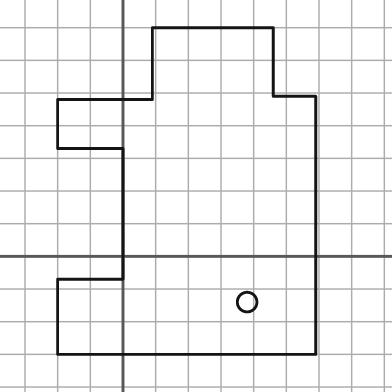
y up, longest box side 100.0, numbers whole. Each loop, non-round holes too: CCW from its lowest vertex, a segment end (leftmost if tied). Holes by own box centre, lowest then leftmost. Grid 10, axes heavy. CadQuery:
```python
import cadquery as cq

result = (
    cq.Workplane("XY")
    .moveTo(-20.0, -30.0)
    .lineTo(59.0, -30.0)
    .lineTo(59.0, 49.0)
    .lineTo(46.0, 49.0)
    .lineTo(46.0, 70.0)
    .lineTo(9.0, 70.0)
    .lineTo(9.0, 48.0)
    .lineTo(-20.0, 48.0)
    .lineTo(-20.0, 33.0)
    .lineTo(0.0, 33.0)
    .lineTo(0.0, -7.0)
    .lineTo(-20.0, -7.0)
    .close()
    .moveTo(38.0, -14.0)
    .circle(3.0)
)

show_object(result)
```